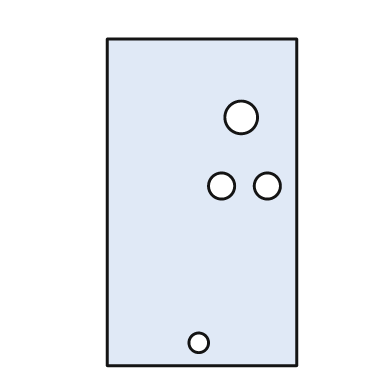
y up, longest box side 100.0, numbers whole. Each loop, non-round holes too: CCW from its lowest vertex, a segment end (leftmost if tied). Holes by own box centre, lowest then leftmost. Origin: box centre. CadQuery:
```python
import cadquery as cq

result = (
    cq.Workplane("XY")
    .moveTo(-29.0, -50.0)
    .lineTo(29.0, -50.0)
    .lineTo(29.0, 50.0)
    .lineTo(-29.0, 50.0)
    .close()
    .moveTo(-1.0, -43.0)
    .circle(3.0)
    .moveTo(6.0, 5.0)
    .circle(4.0)
    .moveTo(20.0, 5.0)
    .circle(4.0)
    .moveTo(12.0, 26.0)
    .circle(5.0)
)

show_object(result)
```